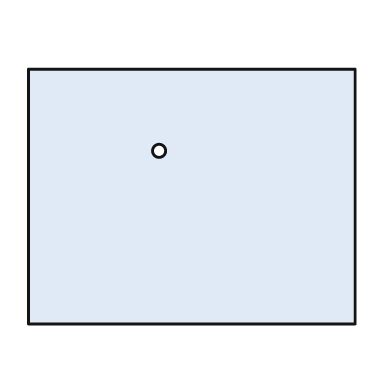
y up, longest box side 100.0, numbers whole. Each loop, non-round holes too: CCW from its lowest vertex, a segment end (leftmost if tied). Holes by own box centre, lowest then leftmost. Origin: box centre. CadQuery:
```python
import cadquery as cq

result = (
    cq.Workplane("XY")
    .moveTo(-50.0, -39.0)
    .lineTo(50.0, -39.0)
    .lineTo(50.0, 39.0)
    .lineTo(-50.0, 39.0)
    .close()
    .moveTo(-10.0, 14.0)
    .circle(2.0)
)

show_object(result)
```